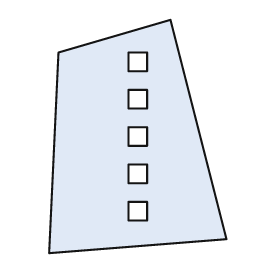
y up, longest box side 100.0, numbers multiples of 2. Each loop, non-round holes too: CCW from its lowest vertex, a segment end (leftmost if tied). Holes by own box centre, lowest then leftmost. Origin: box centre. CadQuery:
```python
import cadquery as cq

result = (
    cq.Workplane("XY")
    .moveTo(-38.0, -50.0)
    .lineTo(38.0, -44.0)
    .lineTo(14.0, 50.0)
    .lineTo(-34.0, 36.0)
    .close()
    .moveTo(-4.0, -36.0)
    .lineTo(4.0, -36.0)
    .lineTo(4.0, -28.0)
    .lineTo(-4.0, -28.0)
    .close()
    .moveTo(-4.0, -20.0)
    .lineTo(4.0, -20.0)
    .lineTo(4.0, -12.0)
    .lineTo(-4.0, -12.0)
    .close()
    .moveTo(-4.0, -4.0)
    .lineTo(4.0, -4.0)
    .lineTo(4.0, 4.0)
    .lineTo(-4.0, 4.0)
    .close()
    .moveTo(-4.0, 12.0)
    .lineTo(4.0, 12.0)
    .lineTo(4.0, 20.0)
    .lineTo(-4.0, 20.0)
    .close()
    .moveTo(-4.0, 28.0)
    .lineTo(4.0, 28.0)
    .lineTo(4.0, 36.0)
    .lineTo(-4.0, 36.0)
    .close()
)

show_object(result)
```